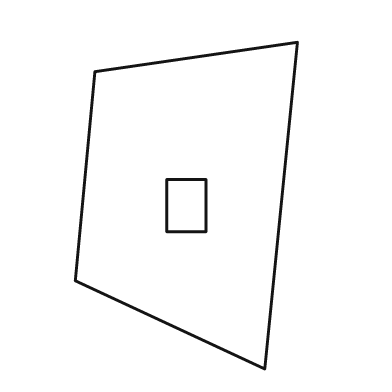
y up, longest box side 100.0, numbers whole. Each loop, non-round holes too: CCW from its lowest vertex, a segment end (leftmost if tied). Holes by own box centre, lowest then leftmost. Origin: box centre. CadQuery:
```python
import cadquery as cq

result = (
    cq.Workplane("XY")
    .moveTo(24.0, -50.0)
    .lineTo(34.0, 50.0)
    .lineTo(-28.0, 41.0)
    .lineTo(-34.0, -23.0)
    .close()
    .moveTo(-6.0, -8.0)
    .lineTo(6.0, -8.0)
    .lineTo(6.0, 8.0)
    .lineTo(-6.0, 8.0)
    .close()
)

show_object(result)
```